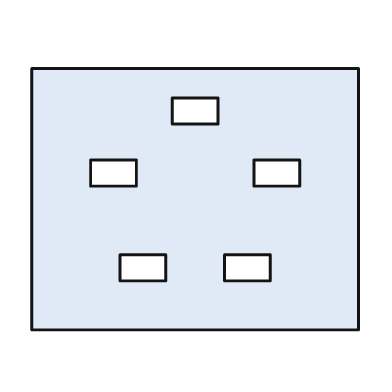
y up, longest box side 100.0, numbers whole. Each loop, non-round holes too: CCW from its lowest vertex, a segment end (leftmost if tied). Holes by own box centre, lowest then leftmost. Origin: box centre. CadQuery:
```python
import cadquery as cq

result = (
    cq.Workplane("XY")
    .moveTo(-50.0, -40.0)
    .lineTo(50.0, -40.0)
    .lineTo(50.0, 40.0)
    .lineTo(-50.0, 40.0)
    .close()
    .moveTo(-23.0, -25.0)
    .lineTo(-9.0, -25.0)
    .lineTo(-9.0, -17.0)
    .lineTo(-23.0, -17.0)
    .close()
    .moveTo(9.0, -25.0)
    .lineTo(23.0, -25.0)
    .lineTo(23.0, -17.0)
    .lineTo(9.0, -17.0)
    .close()
    .moveTo(-32.0, 4.0)
    .lineTo(-18.0, 4.0)
    .lineTo(-18.0, 12.0)
    .lineTo(-32.0, 12.0)
    .close()
    .moveTo(18.0, 4.0)
    .lineTo(32.0, 4.0)
    .lineTo(32.0, 12.0)
    .lineTo(18.0, 12.0)
    .close()
    .moveTo(-7.0, 23.0)
    .lineTo(7.0, 23.0)
    .lineTo(7.0, 31.0)
    .lineTo(-7.0, 31.0)
    .close()
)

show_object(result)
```